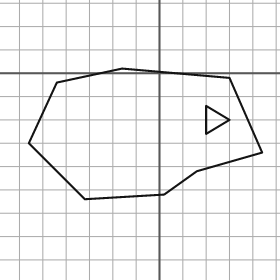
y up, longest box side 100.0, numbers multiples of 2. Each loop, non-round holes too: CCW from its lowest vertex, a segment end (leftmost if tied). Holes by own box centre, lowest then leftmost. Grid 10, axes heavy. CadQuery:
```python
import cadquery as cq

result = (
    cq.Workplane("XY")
    .moveTo(-32.0, -54.0)
    .lineTo(2.0, -52.0)
    .lineTo(16.0, -42.0)
    .lineTo(44.0, -34.0)
    .lineTo(30.0, -2.0)
    .lineTo(-16.0, 2.0)
    .lineTo(-44.0, -4.0)
    .lineTo(-56.0, -30.0)
    .close()
    .moveTo(20.0, -26.0)
    .lineTo(30.0, -20.0)
    .lineTo(20.0, -14.0)
    .close()
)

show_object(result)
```